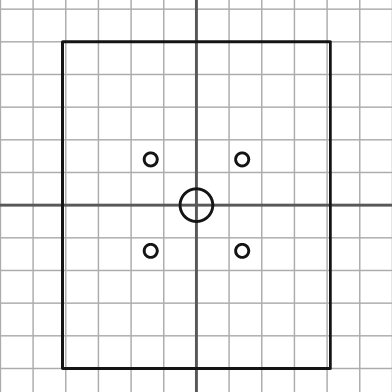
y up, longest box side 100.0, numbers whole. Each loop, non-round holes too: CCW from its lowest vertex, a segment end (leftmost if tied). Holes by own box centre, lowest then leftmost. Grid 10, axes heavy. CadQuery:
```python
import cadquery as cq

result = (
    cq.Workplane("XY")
    .moveTo(-41.0, -50.0)
    .lineTo(41.0, -50.0)
    .lineTo(41.0, 50.0)
    .lineTo(-41.0, 50.0)
    .close()
    .moveTo(-14.0, -14.0)
    .circle(2.0)
    .moveTo(14.0, -14.0)
    .circle(2.0)
    .moveTo(0.0, 0.0)
    .circle(5.0)
    .moveTo(-14.0, 14.0)
    .circle(2.0)
    .moveTo(14.0, 14.0)
    .circle(2.0)
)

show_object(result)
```